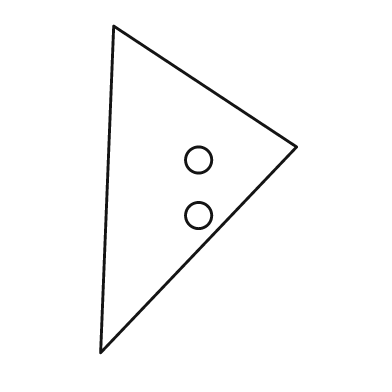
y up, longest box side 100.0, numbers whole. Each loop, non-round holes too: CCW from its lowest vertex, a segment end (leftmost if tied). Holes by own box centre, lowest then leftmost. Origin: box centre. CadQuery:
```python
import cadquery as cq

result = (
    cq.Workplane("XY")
    .moveTo(-30.0, -50.0)
    .lineTo(30.0, 13.0)
    .lineTo(-26.0, 50.0)
    .close()
    .moveTo(0.0, -8.0)
    .circle(4.0)
    .moveTo(0.0, 9.0)
    .circle(4.0)
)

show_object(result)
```